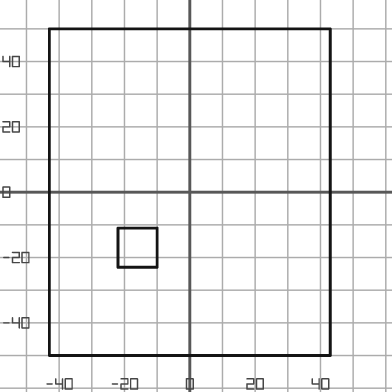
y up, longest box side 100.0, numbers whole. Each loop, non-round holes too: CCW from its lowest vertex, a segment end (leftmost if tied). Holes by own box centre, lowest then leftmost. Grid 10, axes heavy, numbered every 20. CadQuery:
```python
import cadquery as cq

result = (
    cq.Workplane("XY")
    .moveTo(-43.0, -50.0)
    .lineTo(43.0, -50.0)
    .lineTo(43.0, 50.0)
    .lineTo(-43.0, 50.0)
    .close()
    .moveTo(-22.0, -23.0)
    .lineTo(-10.0, -23.0)
    .lineTo(-10.0, -11.0)
    .lineTo(-22.0, -11.0)
    .close()
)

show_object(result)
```